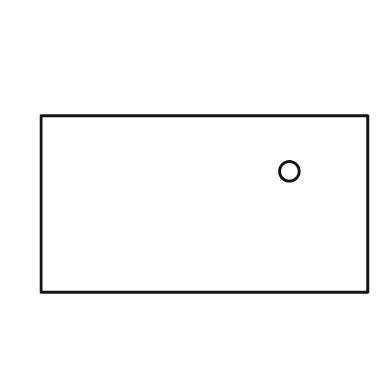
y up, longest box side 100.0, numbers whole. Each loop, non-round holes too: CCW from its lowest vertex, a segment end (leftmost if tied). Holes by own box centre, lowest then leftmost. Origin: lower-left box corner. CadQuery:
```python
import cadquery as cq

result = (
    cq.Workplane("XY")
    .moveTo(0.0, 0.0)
    .lineTo(100.0, 0.0)
    .lineTo(100.0, 54.0)
    .lineTo(0.0, 54.0)
    .close()
    .moveTo(76.0, 37.0)
    .circle(3.0)
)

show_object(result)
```